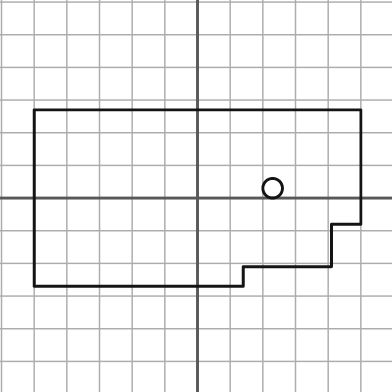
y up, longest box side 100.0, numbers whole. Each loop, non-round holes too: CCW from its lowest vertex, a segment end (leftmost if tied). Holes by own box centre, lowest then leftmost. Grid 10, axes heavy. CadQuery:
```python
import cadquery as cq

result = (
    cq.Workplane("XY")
    .moveTo(-50.0, -27.0)
    .lineTo(14.0, -27.0)
    .lineTo(14.0, -21.0)
    .lineTo(41.0, -21.0)
    .lineTo(41.0, -8.0)
    .lineTo(50.0, -8.0)
    .lineTo(50.0, 27.0)
    .lineTo(-50.0, 27.0)
    .close()
    .moveTo(23.0, 3.0)
    .circle(3.0)
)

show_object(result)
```